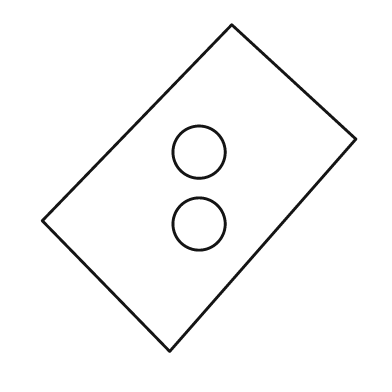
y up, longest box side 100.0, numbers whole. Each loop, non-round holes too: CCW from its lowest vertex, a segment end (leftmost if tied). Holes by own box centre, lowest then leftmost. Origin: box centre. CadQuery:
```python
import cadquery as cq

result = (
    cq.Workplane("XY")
    .moveTo(-9.0, -50.0)
    .lineTo(48.0, 15.0)
    .lineTo(10.0, 50.0)
    .lineTo(-48.0, -10.0)
    .close()
    .moveTo(0.0, -11.0)
    .circle(8.0)
    .moveTo(0.0, 11.0)
    .circle(8.0)
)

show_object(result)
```